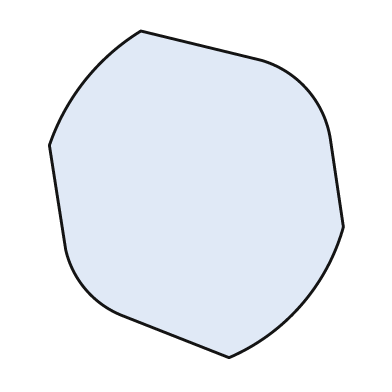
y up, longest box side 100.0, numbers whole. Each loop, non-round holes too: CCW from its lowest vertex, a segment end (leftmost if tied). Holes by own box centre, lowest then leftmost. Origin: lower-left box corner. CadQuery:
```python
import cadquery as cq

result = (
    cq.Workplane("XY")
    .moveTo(55.0, 0.0)
    .threePointArc((77.0, 16.0), (90.0, 40.0))
    .lineTo(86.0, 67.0)
    .threePointArc((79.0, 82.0), (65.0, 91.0))
    .lineTo(28.0, 100.0)
    .threePointArc((11.0, 85.0), (0.0, 65.0))
    .lineTo(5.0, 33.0)
    .threePointArc((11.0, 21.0), (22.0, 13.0))
    .close()
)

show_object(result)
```